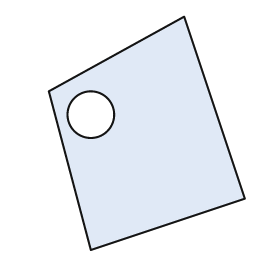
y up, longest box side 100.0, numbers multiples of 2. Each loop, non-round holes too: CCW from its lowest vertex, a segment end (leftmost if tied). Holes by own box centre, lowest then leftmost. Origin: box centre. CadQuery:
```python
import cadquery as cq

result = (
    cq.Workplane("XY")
    .moveTo(-24.0, -50.0)
    .lineTo(42.0, -28.0)
    .lineTo(16.0, 50.0)
    .lineTo(-42.0, 18.0)
    .close()
    .moveTo(-24.0, 8.0)
    .circle(10.0)
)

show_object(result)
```